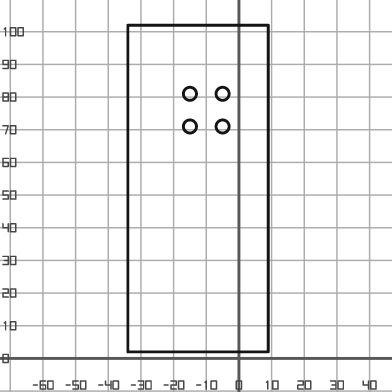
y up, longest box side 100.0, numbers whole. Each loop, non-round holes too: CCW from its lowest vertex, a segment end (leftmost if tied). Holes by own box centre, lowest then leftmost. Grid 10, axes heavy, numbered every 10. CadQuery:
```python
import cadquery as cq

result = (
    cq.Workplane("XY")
    .moveTo(-34.0, 2.0)
    .lineTo(9.0, 2.0)
    .lineTo(9.0, 102.0)
    .lineTo(-34.0, 102.0)
    .close()
    .moveTo(-15.0, 71.0)
    .circle(2.0)
    .moveTo(-5.0, 71.0)
    .circle(2.0)
    .moveTo(-15.0, 81.0)
    .circle(2.0)
    .moveTo(-5.0, 81.0)
    .circle(2.0)
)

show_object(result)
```